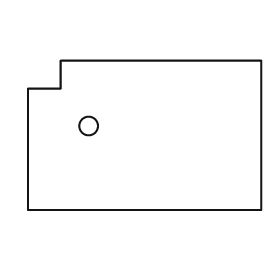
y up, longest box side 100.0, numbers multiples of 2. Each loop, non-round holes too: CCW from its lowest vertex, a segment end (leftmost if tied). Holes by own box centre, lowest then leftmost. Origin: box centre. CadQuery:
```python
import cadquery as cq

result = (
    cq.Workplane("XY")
    .moveTo(-50.0, -32.0)
    .lineTo(50.0, -32.0)
    .lineTo(50.0, 32.0)
    .lineTo(-36.0, 32.0)
    .lineTo(-36.0, 20.0)
    .lineTo(-50.0, 20.0)
    .close()
    .moveTo(-24.0, 4.0)
    .circle(4.0)
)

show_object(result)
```